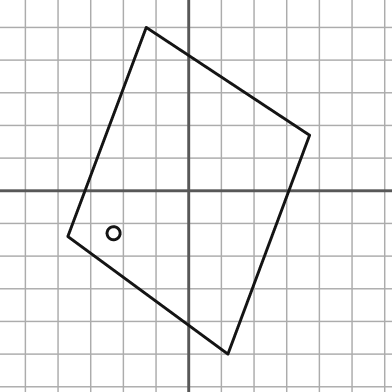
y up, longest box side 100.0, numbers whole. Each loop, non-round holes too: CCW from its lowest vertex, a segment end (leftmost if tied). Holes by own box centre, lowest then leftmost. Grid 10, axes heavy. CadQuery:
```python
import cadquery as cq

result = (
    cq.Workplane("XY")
    .moveTo(12.0, -50.0)
    .lineTo(37.0, 17.0)
    .lineTo(-13.0, 50.0)
    .lineTo(-37.0, -14.0)
    .close()
    .moveTo(-23.0, -13.0)
    .circle(2.0)
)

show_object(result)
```